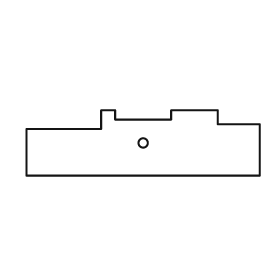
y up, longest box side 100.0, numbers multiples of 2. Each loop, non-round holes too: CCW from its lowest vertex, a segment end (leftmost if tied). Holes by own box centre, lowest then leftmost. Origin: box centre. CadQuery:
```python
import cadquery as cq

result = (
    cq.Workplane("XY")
    .moveTo(-50.0, -14.0)
    .lineTo(50.0, -14.0)
    .lineTo(50.0, 8.0)
    .lineTo(32.0, 8.0)
    .lineTo(32.0, 14.0)
    .lineTo(12.0, 14.0)
    .lineTo(12.0, 10.0)
    .lineTo(-12.0, 10.0)
    .lineTo(-12.0, 14.0)
    .lineTo(-18.0, 14.0)
    .lineTo(-18.0, 6.0)
    .lineTo(-50.0, 6.0)
    .close()
    .moveTo(0.0, 0.0)
    .circle(2.0)
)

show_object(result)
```